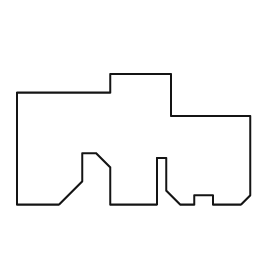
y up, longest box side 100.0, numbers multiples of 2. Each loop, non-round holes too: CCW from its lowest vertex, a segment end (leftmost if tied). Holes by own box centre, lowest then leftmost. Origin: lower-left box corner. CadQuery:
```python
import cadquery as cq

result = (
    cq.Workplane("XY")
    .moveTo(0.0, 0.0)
    .lineTo(18.0, 0.0)
    .lineTo(28.0, 10.0)
    .lineTo(28.0, 22.0)
    .lineTo(34.0, 22.0)
    .lineTo(40.0, 16.0)
    .lineTo(40.0, 0.0)
    .lineTo(60.0, 0.0)
    .lineTo(60.0, 20.0)
    .lineTo(64.0, 20.0)
    .lineTo(64.0, 6.0)
    .lineTo(70.0, 0.0)
    .lineTo(76.0, 0.0)
    .lineTo(76.0, 4.0)
    .lineTo(84.0, 4.0)
    .lineTo(84.0, 0.0)
    .lineTo(96.0, 0.0)
    .lineTo(100.0, 4.0)
    .lineTo(100.0, 38.0)
    .lineTo(66.0, 38.0)
    .lineTo(66.0, 56.0)
    .lineTo(40.0, 56.0)
    .lineTo(40.0, 48.0)
    .lineTo(0.0, 48.0)
    .close()
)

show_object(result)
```